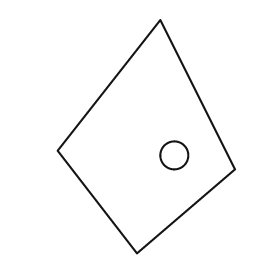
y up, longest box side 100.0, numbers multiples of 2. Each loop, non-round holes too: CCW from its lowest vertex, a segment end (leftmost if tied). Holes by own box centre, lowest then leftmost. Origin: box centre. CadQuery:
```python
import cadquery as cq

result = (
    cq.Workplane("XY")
    .moveTo(-4.0, -50.0)
    .lineTo(38.0, -14.0)
    .lineTo(6.0, 50.0)
    .lineTo(-38.0, -6.0)
    .close()
    .moveTo(12.0, -8.0)
    .circle(6.0)
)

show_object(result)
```